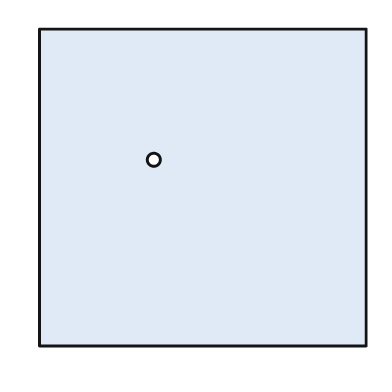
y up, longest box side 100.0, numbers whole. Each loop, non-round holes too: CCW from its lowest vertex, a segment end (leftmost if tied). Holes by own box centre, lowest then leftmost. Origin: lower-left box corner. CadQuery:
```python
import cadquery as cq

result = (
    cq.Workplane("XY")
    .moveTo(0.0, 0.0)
    .lineTo(100.0, 0.0)
    .lineTo(100.0, 97.0)
    .lineTo(0.0, 97.0)
    .close()
    .moveTo(35.0, 57.0)
    .circle(2.0)
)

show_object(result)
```